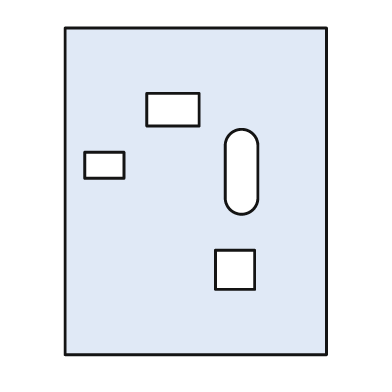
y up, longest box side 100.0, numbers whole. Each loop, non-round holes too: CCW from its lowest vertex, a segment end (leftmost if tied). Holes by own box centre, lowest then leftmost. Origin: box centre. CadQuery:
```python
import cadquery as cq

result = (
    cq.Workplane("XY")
    .moveTo(-40.0, -50.0)
    .lineTo(40.0, -50.0)
    .lineTo(40.0, 50.0)
    .lineTo(-40.0, 50.0)
    .close()
    .moveTo(6.0, -30.0)
    .lineTo(18.0, -30.0)
    .lineTo(18.0, -18.0)
    .lineTo(6.0, -18.0)
    .close()
    .moveTo(9.0, -2.0)
    .threePointArc((14.0, -7.0), (19.0, -2.0))
    .lineTo(19.0, 14.0)
    .threePointArc((14.0, 19.0), (9.0, 14.0))
    .close()
    .moveTo(-34.0, 4.0)
    .lineTo(-22.0, 4.0)
    .lineTo(-22.0, 12.0)
    .lineTo(-34.0, 12.0)
    .close()
    .moveTo(-15.0, 20.0)
    .lineTo(1.0, 20.0)
    .lineTo(1.0, 30.0)
    .lineTo(-15.0, 30.0)
    .close()
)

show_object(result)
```